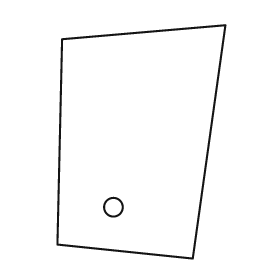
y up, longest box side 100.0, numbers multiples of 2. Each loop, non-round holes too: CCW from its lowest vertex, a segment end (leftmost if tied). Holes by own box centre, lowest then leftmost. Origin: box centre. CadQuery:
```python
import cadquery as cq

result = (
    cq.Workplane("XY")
    .moveTo(22.0, -50.0)
    .lineTo(36.0, 50.0)
    .lineTo(-34.0, 44.0)
    .lineTo(-36.0, -44.0)
    .close()
    .moveTo(-12.0, -28.0)
    .circle(4.0)
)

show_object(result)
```